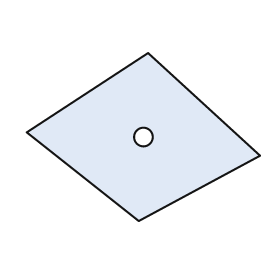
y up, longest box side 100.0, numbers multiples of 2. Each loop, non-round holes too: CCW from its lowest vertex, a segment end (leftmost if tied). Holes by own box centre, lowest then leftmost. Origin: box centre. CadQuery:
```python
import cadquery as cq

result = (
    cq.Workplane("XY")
    .moveTo(-2.0, -36.0)
    .lineTo(50.0, -8.0)
    .lineTo(2.0, 36.0)
    .lineTo(-50.0, 2.0)
    .close()
    .moveTo(0.0, 0.0)
    .circle(4.0)
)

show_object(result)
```